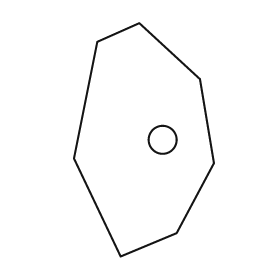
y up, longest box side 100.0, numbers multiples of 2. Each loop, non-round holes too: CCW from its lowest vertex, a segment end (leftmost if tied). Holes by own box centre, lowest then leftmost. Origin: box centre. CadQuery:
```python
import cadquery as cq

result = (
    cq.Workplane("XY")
    .moveTo(-10.0, -50.0)
    .lineTo(14.0, -40.0)
    .lineTo(30.0, -10.0)
    .lineTo(24.0, 26.0)
    .lineTo(-2.0, 50.0)
    .lineTo(-20.0, 42.0)
    .lineTo(-30.0, -8.0)
    .close()
    .moveTo(8.0, 0.0)
    .circle(6.0)
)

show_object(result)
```